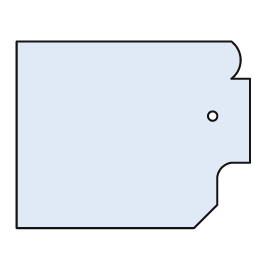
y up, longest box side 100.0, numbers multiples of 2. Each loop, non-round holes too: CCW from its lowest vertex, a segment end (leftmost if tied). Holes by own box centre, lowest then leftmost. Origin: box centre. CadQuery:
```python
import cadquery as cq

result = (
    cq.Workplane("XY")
    .moveTo(-50.0, -40.0)
    .lineTo(26.0, -40.0)
    .lineTo(36.0, -30.0)
    .lineTo(36.0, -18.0)
    .threePointArc((38.0, -14.0), (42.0, -12.0))
    .lineTo(50.0, -12.0)
    .lineTo(50.0, 24.0)
    .lineTo(42.0, 24.0)
    .threePointArc((46.0, 32.0), (42.0, 40.0))
    .lineTo(-50.0, 40.0)
    .close()
    .moveTo(34.0, 8.0)
    .circle(2.0)
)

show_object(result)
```